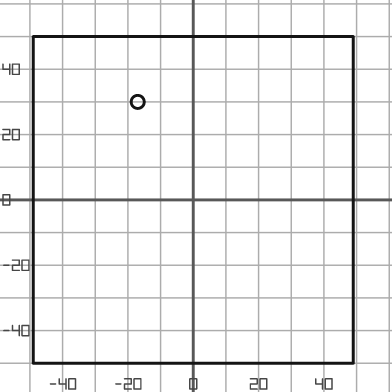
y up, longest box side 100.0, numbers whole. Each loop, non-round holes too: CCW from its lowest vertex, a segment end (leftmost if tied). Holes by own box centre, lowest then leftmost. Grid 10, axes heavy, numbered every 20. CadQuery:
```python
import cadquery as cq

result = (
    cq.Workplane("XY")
    .moveTo(-49.0, -50.0)
    .lineTo(49.0, -50.0)
    .lineTo(49.0, 50.0)
    .lineTo(-49.0, 50.0)
    .close()
    .moveTo(-17.0, 30.0)
    .circle(2.0)
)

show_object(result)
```